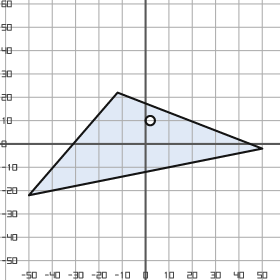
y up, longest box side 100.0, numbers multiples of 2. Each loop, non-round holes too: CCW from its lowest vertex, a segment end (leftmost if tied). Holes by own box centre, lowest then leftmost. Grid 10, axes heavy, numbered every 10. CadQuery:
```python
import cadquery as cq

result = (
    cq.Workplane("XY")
    .moveTo(-50.0, -22.0)
    .lineTo(50.0, -2.0)
    .lineTo(-12.0, 22.0)
    .close()
    .moveTo(2.0, 10.0)
    .circle(2.0)
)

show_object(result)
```